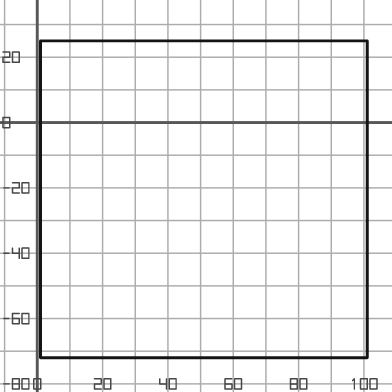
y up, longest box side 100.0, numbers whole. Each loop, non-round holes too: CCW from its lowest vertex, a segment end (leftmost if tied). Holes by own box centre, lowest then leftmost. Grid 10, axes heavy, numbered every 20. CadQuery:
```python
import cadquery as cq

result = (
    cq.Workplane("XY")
    .moveTo(1.0, -72.0)
    .lineTo(101.0, -72.0)
    .lineTo(101.0, 25.0)
    .lineTo(1.0, 25.0)
    .close()
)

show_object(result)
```